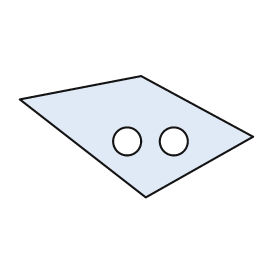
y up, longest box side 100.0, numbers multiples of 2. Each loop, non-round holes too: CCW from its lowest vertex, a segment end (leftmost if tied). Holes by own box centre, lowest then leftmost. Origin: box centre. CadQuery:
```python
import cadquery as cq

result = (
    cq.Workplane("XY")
    .moveTo(4.0, -26.0)
    .lineTo(50.0, 0.0)
    .lineTo(2.0, 26.0)
    .lineTo(-50.0, 16.0)
    .close()
    .moveTo(-4.0, -2.0)
    .circle(6.0)
    .moveTo(16.0, -2.0)
    .circle(6.0)
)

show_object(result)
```